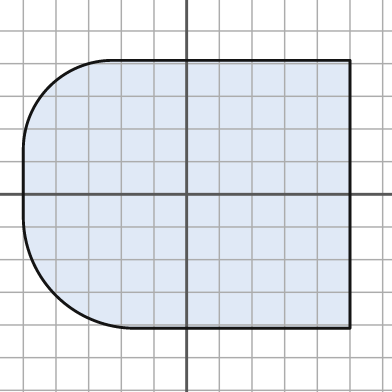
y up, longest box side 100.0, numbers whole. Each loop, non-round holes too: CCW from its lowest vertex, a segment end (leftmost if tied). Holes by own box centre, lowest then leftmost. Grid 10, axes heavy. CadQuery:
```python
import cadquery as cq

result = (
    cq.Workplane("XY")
    .moveTo(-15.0, -41.0)
    .lineTo(50.0, -41.0)
    .lineTo(50.0, 41.0)
    .lineTo(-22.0, 41.0)
    .threePointArc((-42.0, 33.0), (-50.0, 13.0))
    .lineTo(-50.0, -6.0)
    .threePointArc((-40.0, -31.0), (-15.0, -41.0))
    .close()
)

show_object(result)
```